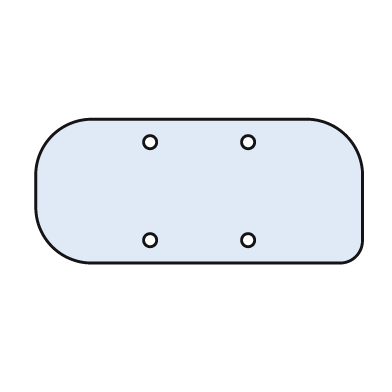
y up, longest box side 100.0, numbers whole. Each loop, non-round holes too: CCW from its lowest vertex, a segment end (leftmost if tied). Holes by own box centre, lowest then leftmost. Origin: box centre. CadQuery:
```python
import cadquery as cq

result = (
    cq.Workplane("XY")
    .moveTo(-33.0, -22.0)
    .lineTo(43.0, -22.0)
    .threePointArc((48.0, -20.0), (50.0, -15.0))
    .lineTo(50.0, 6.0)
    .threePointArc((45.0, 17.0), (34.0, 22.0))
    .lineTo(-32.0, 22.0)
    .threePointArc((-45.0, 17.0), (-50.0, 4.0))
    .lineTo(-50.0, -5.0)
    .threePointArc((-45.0, -17.0), (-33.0, -22.0))
    .close()
    .moveTo(-15.0, -15.0)
    .circle(2.0)
    .moveTo(15.0, -15.0)
    .circle(2.0)
    .moveTo(-15.0, 15.0)
    .circle(2.0)
    .moveTo(15.0, 15.0)
    .circle(2.0)
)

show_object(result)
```